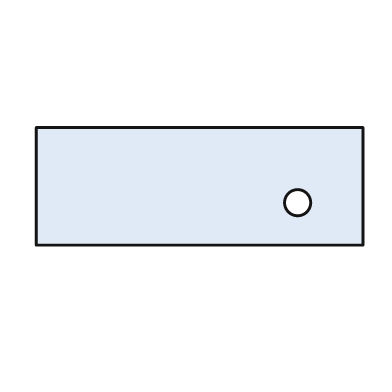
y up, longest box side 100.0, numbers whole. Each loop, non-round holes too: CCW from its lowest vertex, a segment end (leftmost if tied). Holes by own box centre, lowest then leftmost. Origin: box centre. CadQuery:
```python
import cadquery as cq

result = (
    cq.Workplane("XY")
    .moveTo(-50.0, -18.0)
    .lineTo(50.0, -18.0)
    .lineTo(50.0, 18.0)
    .lineTo(-50.0, 18.0)
    .close()
    .moveTo(30.0, -5.0)
    .circle(4.0)
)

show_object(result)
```